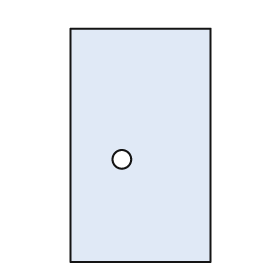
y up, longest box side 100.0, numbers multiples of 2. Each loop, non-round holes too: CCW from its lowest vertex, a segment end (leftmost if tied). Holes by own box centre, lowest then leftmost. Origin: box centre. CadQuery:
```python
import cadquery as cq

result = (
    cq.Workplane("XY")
    .moveTo(-30.0, -50.0)
    .lineTo(30.0, -50.0)
    .lineTo(30.0, 50.0)
    .lineTo(-30.0, 50.0)
    .close()
    .moveTo(-8.0, -6.0)
    .circle(4.0)
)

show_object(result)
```